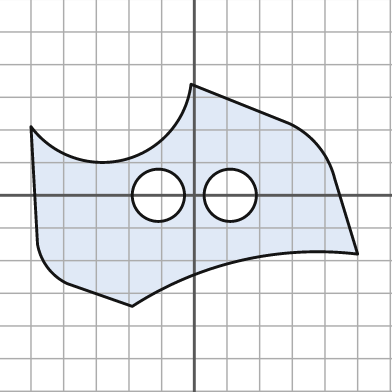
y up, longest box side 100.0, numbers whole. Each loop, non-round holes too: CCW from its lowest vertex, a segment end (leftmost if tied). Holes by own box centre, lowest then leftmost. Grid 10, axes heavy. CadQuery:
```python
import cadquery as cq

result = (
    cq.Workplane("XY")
    .moveTo(-19.0, -34.0)
    .threePointArc((14.0, -20.0), (50.0, -18.0))
    .lineTo(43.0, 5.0)
    .threePointArc((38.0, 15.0), (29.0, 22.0))
    .lineTo(-1.0, 34.0)
    .threePointArc((-21.0, 11.0), (-50.0, 21.0))
    .lineTo(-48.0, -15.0)
    .threePointArc((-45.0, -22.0), (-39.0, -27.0))
    .close()
    .moveTo(-11.0, 0.0)
    .circle(8.0)
    .moveTo(11.0, 0.0)
    .circle(8.0)
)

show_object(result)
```